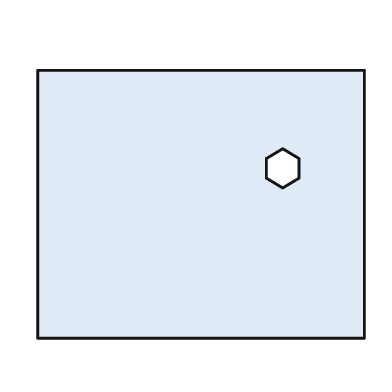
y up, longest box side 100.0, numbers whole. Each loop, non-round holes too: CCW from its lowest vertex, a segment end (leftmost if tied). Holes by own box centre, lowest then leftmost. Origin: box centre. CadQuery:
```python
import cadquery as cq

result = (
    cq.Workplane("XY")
    .moveTo(-50.0, -41.0)
    .lineTo(50.0, -41.0)
    .lineTo(50.0, 41.0)
    .lineTo(-50.0, 41.0)
    .close()
    .moveTo(25.0, 5.0)
    .lineTo(30.0, 8.0)
    .lineTo(30.0, 14.0)
    .lineTo(25.0, 17.0)
    .lineTo(20.0, 14.0)
    .lineTo(20.0, 8.0)
    .close()
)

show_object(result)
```